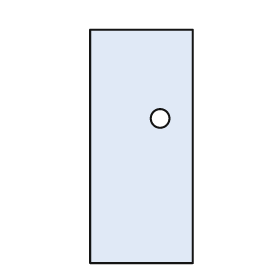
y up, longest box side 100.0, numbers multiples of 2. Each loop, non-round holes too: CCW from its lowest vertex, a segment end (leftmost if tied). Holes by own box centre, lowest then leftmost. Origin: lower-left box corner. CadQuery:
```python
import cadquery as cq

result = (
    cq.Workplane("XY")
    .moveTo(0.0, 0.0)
    .lineTo(44.0, 0.0)
    .lineTo(44.0, 100.0)
    .lineTo(0.0, 100.0)
    .close()
    .moveTo(30.0, 62.0)
    .circle(4.0)
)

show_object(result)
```